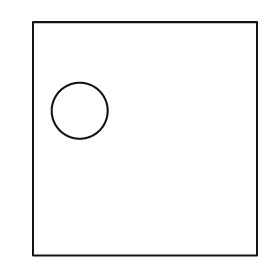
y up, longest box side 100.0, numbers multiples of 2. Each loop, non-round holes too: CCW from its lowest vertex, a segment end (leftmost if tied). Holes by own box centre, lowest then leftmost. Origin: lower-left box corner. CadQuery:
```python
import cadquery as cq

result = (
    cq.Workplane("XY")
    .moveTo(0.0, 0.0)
    .lineTo(96.0, 0.0)
    .lineTo(96.0, 100.0)
    .lineTo(0.0, 100.0)
    .close()
    .moveTo(20.0, 62.0)
    .circle(12.0)
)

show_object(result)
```